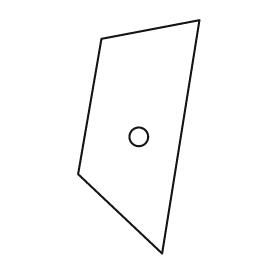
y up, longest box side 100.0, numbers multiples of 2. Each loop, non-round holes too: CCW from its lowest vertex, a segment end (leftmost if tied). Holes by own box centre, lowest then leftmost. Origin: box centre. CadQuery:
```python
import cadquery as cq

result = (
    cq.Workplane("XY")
    .moveTo(10.0, -50.0)
    .lineTo(26.0, 50.0)
    .lineTo(-16.0, 42.0)
    .lineTo(-26.0, -16.0)
    .close()
    .moveTo(0.0, 0.0)
    .circle(4.0)
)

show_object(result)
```